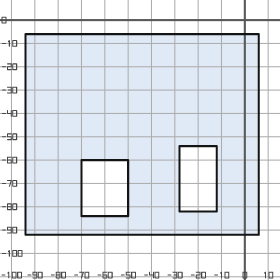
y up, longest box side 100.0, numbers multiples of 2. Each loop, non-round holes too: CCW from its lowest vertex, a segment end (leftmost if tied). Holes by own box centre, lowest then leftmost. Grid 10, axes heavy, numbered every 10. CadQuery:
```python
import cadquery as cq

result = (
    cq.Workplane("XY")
    .moveTo(-94.0, -92.0)
    .lineTo(6.0, -92.0)
    .lineTo(6.0, -6.0)
    .lineTo(-94.0, -6.0)
    .close()
    .moveTo(-70.0, -84.0)
    .lineTo(-50.0, -84.0)
    .lineTo(-50.0, -60.0)
    .lineTo(-70.0, -60.0)
    .close()
    .moveTo(-28.0, -82.0)
    .lineTo(-12.0, -82.0)
    .lineTo(-12.0, -54.0)
    .lineTo(-28.0, -54.0)
    .close()
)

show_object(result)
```